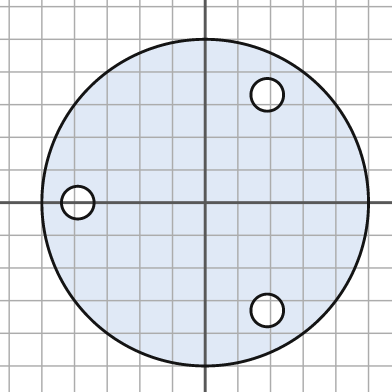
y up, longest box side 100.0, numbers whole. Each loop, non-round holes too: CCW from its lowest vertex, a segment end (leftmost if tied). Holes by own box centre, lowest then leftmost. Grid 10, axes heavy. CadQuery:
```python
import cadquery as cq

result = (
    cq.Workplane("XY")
    .moveTo(0.0, 0.0)
    .circle(50.0)
    .moveTo(19.0, -33.0)
    .circle(5.0)
    .moveTo(-39.0, 0.0)
    .circle(5.0)
    .moveTo(19.0, 33.0)
    .circle(5.0)
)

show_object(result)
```